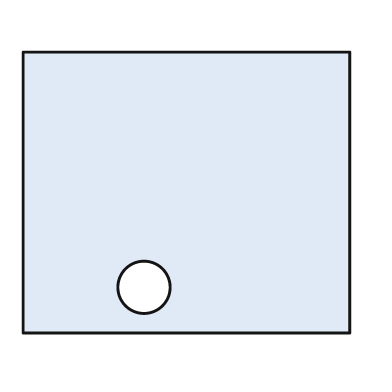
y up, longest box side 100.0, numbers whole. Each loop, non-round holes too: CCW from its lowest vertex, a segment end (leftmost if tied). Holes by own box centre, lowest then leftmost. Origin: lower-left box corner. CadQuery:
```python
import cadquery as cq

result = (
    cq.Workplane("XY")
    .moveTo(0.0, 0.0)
    .lineTo(100.0, 0.0)
    .lineTo(100.0, 86.0)
    .lineTo(0.0, 86.0)
    .close()
    .moveTo(37.0, 14.0)
    .circle(8.0)
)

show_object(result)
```